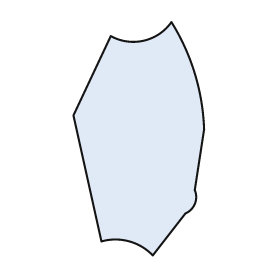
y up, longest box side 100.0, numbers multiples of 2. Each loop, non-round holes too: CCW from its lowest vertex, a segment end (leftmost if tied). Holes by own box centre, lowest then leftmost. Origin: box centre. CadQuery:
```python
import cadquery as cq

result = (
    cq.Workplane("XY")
    .moveTo(6.0, -50.0)
    .lineTo(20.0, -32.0)
    .threePointArc((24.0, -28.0), (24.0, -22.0))
    .lineTo(28.0, 4.0)
    .threePointArc((24.0, 28.0), (14.0, 50.0))
    .threePointArc((2.0, 42.0), (-12.0, 44.0))
    .lineTo(-28.0, 10.0)
    .lineTo(-16.0, -44.0)
    .threePointArc((-4.0, -44.0), (6.0, -50.0))
    .close()
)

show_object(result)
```